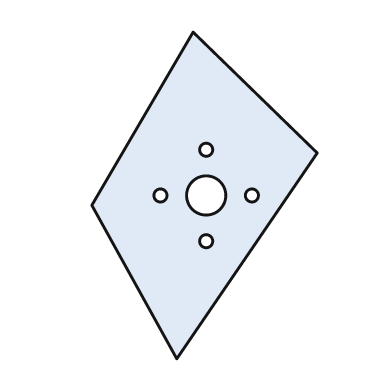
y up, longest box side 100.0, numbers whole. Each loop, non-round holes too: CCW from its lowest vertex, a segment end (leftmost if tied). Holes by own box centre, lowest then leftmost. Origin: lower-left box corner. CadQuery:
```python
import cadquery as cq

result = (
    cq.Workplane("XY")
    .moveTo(26.0, 0.0)
    .lineTo(69.0, 63.0)
    .lineTo(31.0, 100.0)
    .lineTo(0.0, 47.0)
    .close()
    .moveTo(35.0, 36.0)
    .circle(2.0)
    .moveTo(21.0, 50.0)
    .circle(2.0)
    .moveTo(35.0, 50.0)
    .circle(6.0)
    .moveTo(49.0, 50.0)
    .circle(2.0)
    .moveTo(35.0, 64.0)
    .circle(2.0)
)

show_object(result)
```